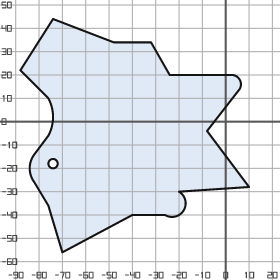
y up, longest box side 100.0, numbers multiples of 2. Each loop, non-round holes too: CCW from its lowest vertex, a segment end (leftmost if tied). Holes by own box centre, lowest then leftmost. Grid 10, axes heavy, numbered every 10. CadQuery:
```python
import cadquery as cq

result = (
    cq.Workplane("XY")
    .moveTo(-70.0, -56.0)
    .lineTo(-40.0, -40.0)
    .lineTo(-26.0, -40.0)
    .threePointArc((-18.0, -38.0), (-20.0, -30.0))
    .lineTo(10.0, -28.0)
    .lineTo(-8.0, -4.0)
    .lineTo(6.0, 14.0)
    .threePointArc((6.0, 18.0), (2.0, 20.0))
    .lineTo(-24.0, 20.0)
    .lineTo(-32.0, 34.0)
    .lineTo(-48.0, 34.0)
    .lineTo(-74.0, 44.0)
    .lineTo(-88.0, 22.0)
    .lineTo(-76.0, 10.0)
    .threePointArc((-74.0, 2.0), (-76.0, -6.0))
    .lineTo(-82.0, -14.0)
    .threePointArc((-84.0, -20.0), (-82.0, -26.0))
    .lineTo(-76.0, -36.0)
    .close()
    .moveTo(-74.0, -18.0)
    .circle(2.0)
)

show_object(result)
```